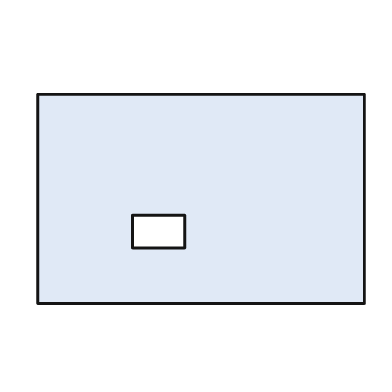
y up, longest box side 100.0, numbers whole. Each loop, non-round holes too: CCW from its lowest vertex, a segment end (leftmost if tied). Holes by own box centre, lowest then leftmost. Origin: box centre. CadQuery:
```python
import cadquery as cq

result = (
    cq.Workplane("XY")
    .moveTo(-50.0, -32.0)
    .lineTo(50.0, -32.0)
    .lineTo(50.0, 32.0)
    .lineTo(-50.0, 32.0)
    .close()
    .moveTo(-21.0, -15.0)
    .lineTo(-5.0, -15.0)
    .lineTo(-5.0, -5.0)
    .lineTo(-21.0, -5.0)
    .close()
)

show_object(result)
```